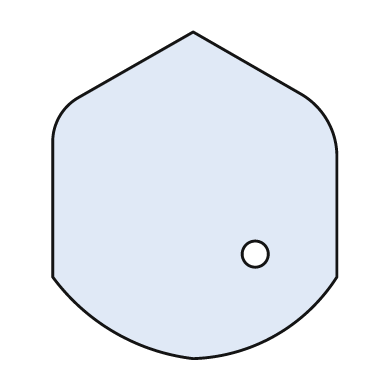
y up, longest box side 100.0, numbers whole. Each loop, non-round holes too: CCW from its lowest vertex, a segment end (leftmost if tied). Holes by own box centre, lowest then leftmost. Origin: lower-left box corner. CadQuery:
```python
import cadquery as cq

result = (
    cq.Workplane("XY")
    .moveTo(43.0, 0.0)
    .threePointArc((68.0, 7.0), (87.0, 25.0))
    .lineTo(87.0, 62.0)
    .threePointArc((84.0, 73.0), (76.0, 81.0))
    .lineTo(43.0, 100.0)
    .lineTo(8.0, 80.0)
    .threePointArc((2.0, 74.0), (0.0, 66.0))
    .lineTo(0.0, 25.0)
    .threePointArc((19.0, 8.0), (43.0, 0.0))
    .close()
    .moveTo(62.0, 32.0)
    .circle(4.0)
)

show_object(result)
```